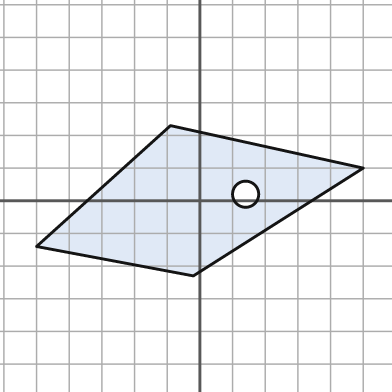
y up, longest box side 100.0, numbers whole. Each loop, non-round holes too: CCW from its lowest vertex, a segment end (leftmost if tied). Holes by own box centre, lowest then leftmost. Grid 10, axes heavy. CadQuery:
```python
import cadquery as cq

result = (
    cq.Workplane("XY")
    .moveTo(-2.0, -23.0)
    .lineTo(50.0, 10.0)
    .lineTo(-9.0, 23.0)
    .lineTo(-50.0, -14.0)
    .close()
    .moveTo(14.0, 2.0)
    .circle(4.0)
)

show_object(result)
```